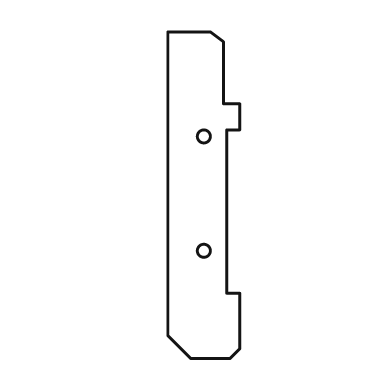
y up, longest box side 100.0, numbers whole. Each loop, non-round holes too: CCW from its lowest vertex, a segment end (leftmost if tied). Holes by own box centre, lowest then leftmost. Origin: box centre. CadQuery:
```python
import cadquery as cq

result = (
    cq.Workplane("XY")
    .moveTo(-4.0, -50.0)
    .lineTo(8.0, -50.0)
    .lineTo(11.0, -47.0)
    .lineTo(11.0, -30.0)
    .lineTo(7.0, -30.0)
    .lineTo(7.0, 20.0)
    .lineTo(11.0, 20.0)
    .lineTo(11.0, 28.0)
    .lineTo(6.0, 28.0)
    .lineTo(6.0, 47.0)
    .lineTo(2.0, 50.0)
    .lineTo(-11.0, 50.0)
    .lineTo(-11.0, -43.0)
    .close()
    .moveTo(0.0, -17.0)
    .circle(2.0)
    .moveTo(0.0, 18.0)
    .circle(2.0)
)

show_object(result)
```